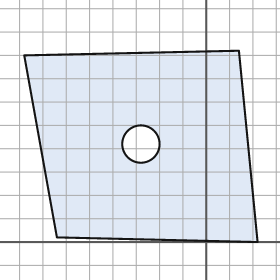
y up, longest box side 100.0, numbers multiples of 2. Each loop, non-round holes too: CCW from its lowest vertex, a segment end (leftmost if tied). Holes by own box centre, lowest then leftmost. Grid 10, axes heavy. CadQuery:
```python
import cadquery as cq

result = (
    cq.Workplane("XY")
    .moveTo(22.0, 0.0)
    .lineTo(14.0, 82.0)
    .lineTo(-78.0, 80.0)
    .lineTo(-64.0, 2.0)
    .close()
    .moveTo(-28.0, 42.0)
    .circle(8.0)
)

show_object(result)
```